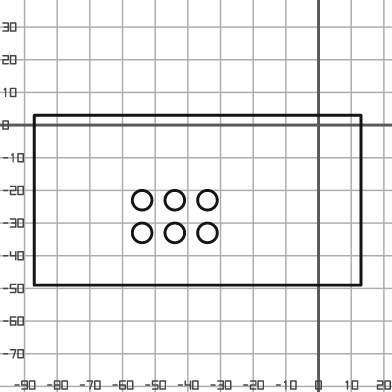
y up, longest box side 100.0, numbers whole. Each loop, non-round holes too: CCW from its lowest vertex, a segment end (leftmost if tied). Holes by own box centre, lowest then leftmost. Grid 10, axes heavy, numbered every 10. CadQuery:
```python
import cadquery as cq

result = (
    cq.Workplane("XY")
    .moveTo(-87.0, -49.0)
    .lineTo(13.0, -49.0)
    .lineTo(13.0, 3.0)
    .lineTo(-87.0, 3.0)
    .close()
    .moveTo(-54.0, -33.0)
    .circle(3.0)
    .moveTo(-44.0, -33.0)
    .circle(3.0)
    .moveTo(-34.0, -33.0)
    .circle(3.0)
    .moveTo(-54.0, -23.0)
    .circle(3.0)
    .moveTo(-44.0, -23.0)
    .circle(3.0)
    .moveTo(-34.0, -23.0)
    .circle(3.0)
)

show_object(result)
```